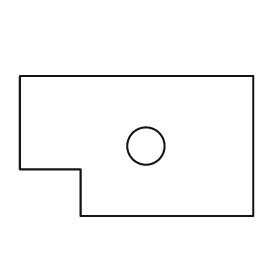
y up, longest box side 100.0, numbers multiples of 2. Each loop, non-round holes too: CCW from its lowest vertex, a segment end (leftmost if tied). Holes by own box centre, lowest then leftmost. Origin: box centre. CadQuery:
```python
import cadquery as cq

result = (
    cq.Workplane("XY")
    .moveTo(-24.0, -30.0)
    .lineTo(50.0, -30.0)
    .lineTo(50.0, 30.0)
    .lineTo(-50.0, 30.0)
    .lineTo(-50.0, -10.0)
    .lineTo(-24.0, -10.0)
    .close()
    .moveTo(4.0, 0.0)
    .circle(8.0)
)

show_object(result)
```